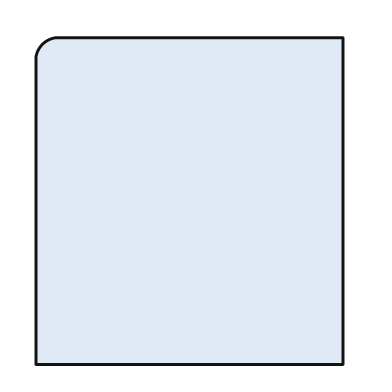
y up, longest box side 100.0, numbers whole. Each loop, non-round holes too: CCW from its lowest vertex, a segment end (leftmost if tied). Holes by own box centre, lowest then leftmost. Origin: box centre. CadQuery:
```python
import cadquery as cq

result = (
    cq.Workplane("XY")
    .moveTo(-47.0, -50.0)
    .lineTo(47.0, -50.0)
    .lineTo(47.0, 50.0)
    .lineTo(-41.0, 50.0)
    .threePointArc((-45.0, 48.0), (-47.0, 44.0))
    .close()
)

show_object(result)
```